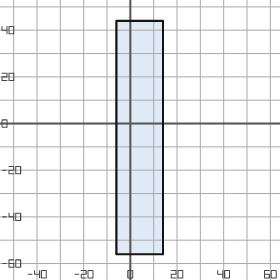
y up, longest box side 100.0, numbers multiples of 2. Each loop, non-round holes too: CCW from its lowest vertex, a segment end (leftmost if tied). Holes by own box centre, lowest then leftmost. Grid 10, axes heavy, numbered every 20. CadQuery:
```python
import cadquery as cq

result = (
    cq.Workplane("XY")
    .moveTo(-6.0, -56.0)
    .lineTo(14.0, -56.0)
    .lineTo(14.0, 44.0)
    .lineTo(-6.0, 44.0)
    .close()
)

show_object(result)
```